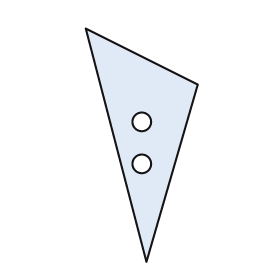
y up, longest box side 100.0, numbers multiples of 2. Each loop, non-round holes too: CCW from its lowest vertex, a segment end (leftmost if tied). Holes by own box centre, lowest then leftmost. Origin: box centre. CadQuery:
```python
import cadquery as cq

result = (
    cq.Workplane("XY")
    .moveTo(2.0, -50.0)
    .lineTo(24.0, 26.0)
    .lineTo(-24.0, 50.0)
    .close()
    .moveTo(0.0, -8.0)
    .circle(4.0)
    .moveTo(0.0, 10.0)
    .circle(4.0)
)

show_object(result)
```